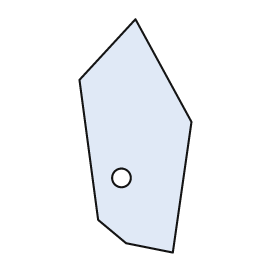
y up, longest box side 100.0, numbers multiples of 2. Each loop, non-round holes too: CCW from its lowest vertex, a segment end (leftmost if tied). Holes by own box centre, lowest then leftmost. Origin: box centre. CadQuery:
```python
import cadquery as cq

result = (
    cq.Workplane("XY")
    .moveTo(16.0, -50.0)
    .lineTo(24.0, 6.0)
    .lineTo(0.0, 50.0)
    .lineTo(-24.0, 24.0)
    .lineTo(-16.0, -36.0)
    .lineTo(-4.0, -46.0)
    .close()
    .moveTo(-6.0, -18.0)
    .circle(4.0)
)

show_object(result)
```